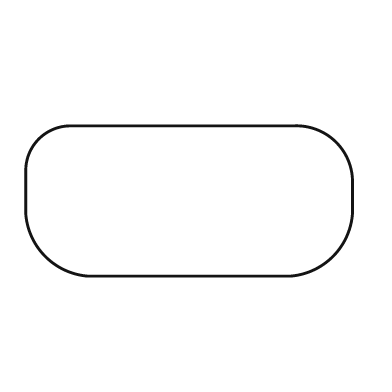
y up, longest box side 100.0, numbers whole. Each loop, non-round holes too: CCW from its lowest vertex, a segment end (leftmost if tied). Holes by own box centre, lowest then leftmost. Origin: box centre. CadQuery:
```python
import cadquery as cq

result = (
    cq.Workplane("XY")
    .moveTo(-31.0, -23.0)
    .lineTo(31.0, -23.0)
    .threePointArc((44.0, -17.0), (50.0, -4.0))
    .lineTo(50.0, 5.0)
    .threePointArc((45.0, 18.0), (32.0, 23.0))
    .lineTo(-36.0, 23.0)
    .threePointArc((-46.0, 19.0), (-50.0, 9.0))
    .lineTo(-50.0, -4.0)
    .threePointArc((-44.0, -17.0), (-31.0, -23.0))
    .close()
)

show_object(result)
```